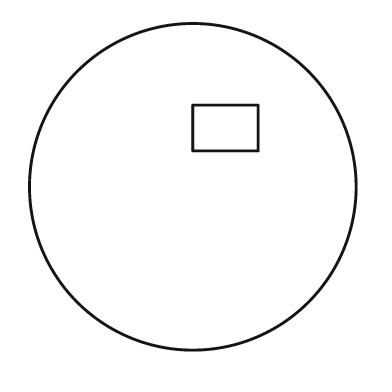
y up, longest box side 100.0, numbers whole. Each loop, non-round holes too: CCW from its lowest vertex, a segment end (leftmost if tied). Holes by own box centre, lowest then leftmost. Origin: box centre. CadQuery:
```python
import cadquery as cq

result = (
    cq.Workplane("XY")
    .moveTo(0.0, 0.0)
    .circle(50.0)
    .moveTo(0.0, 11.0)
    .lineTo(20.0, 11.0)
    .lineTo(20.0, 25.0)
    .lineTo(0.0, 25.0)
    .close()
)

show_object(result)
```